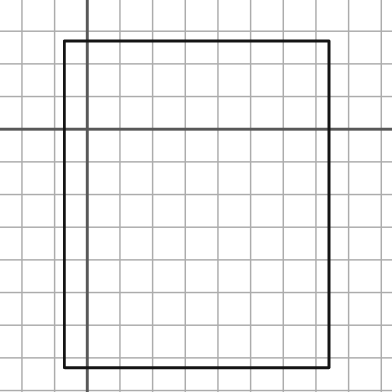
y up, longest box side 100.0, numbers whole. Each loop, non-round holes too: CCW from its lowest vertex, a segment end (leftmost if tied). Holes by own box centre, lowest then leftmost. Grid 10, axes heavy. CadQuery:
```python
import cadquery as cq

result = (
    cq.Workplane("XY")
    .moveTo(-7.0, -73.0)
    .lineTo(74.0, -73.0)
    .lineTo(74.0, 27.0)
    .lineTo(-7.0, 27.0)
    .close()
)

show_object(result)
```